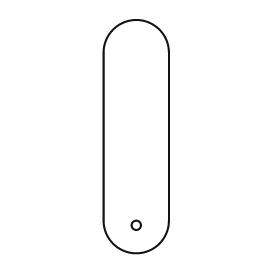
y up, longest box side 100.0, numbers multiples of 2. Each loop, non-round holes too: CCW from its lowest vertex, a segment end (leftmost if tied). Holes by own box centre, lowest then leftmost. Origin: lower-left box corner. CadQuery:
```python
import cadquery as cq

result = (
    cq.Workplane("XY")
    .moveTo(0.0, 14.0)
    .threePointArc((14.0, 0.0), (28.0, 14.0))
    .lineTo(28.0, 86.0)
    .threePointArc((14.0, 100.0), (0.0, 86.0))
    .close()
    .moveTo(14.0, 12.0)
    .circle(2.0)
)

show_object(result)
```